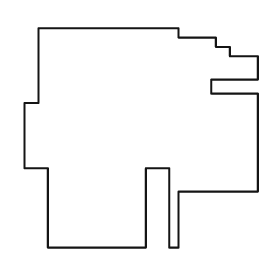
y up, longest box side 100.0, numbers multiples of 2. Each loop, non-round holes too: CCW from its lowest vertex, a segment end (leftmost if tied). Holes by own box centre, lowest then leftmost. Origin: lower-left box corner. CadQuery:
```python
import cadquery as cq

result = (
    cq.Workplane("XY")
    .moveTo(10.0, 0.0)
    .lineTo(52.0, 0.0)
    .lineTo(52.0, 34.0)
    .lineTo(62.0, 34.0)
    .lineTo(62.0, 0.0)
    .lineTo(66.0, 0.0)
    .lineTo(66.0, 24.0)
    .lineTo(100.0, 24.0)
    .lineTo(100.0, 66.0)
    .lineTo(80.0, 66.0)
    .lineTo(80.0, 72.0)
    .lineTo(100.0, 72.0)
    .lineTo(100.0, 82.0)
    .lineTo(88.0, 82.0)
    .lineTo(88.0, 86.0)
    .lineTo(82.0, 86.0)
    .lineTo(82.0, 90.0)
    .lineTo(66.0, 90.0)
    .lineTo(66.0, 94.0)
    .lineTo(6.0, 94.0)
    .lineTo(6.0, 62.0)
    .lineTo(0.0, 62.0)
    .lineTo(0.0, 34.0)
    .lineTo(10.0, 34.0)
    .close()
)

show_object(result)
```